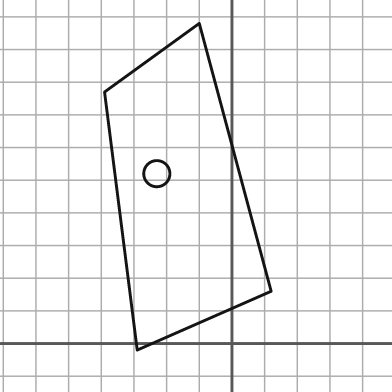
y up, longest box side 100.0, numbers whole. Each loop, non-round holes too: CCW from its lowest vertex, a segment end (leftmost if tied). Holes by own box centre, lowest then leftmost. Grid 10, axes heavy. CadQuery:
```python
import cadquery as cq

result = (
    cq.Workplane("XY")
    .moveTo(-29.0, -2.0)
    .lineTo(12.0, 16.0)
    .lineTo(-10.0, 98.0)
    .lineTo(-39.0, 77.0)
    .close()
    .moveTo(-23.0, 52.0)
    .circle(4.0)
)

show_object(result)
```